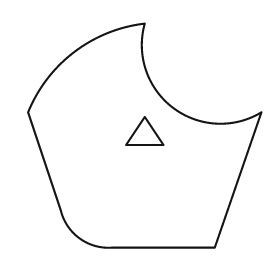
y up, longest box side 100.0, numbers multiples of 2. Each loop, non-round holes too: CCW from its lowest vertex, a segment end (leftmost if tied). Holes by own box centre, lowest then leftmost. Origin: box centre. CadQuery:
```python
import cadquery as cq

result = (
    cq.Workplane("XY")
    .moveTo(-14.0, -48.0)
    .lineTo(30.0, -48.0)
    .lineTo(50.0, 10.0)
    .threePointArc((12.0, 12.0), (0.0, 48.0))
    .threePointArc((-30.0, 36.0), (-50.0, 10.0))
    .lineTo(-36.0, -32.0)
    .threePointArc((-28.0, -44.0), (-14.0, -48.0))
    .close()
    .moveTo(-8.0, -4.0)
    .lineTo(8.0, -4.0)
    .lineTo(0.0, 8.0)
    .close()
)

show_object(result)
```